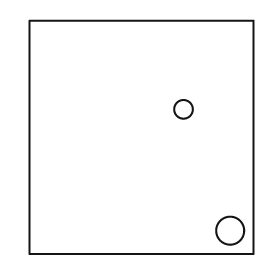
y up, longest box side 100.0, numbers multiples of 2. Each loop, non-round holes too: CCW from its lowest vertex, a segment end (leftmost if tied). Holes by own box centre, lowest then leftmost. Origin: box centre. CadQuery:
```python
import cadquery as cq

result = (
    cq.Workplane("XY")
    .moveTo(-48.0, -50.0)
    .lineTo(48.0, -50.0)
    .lineTo(48.0, 50.0)
    .lineTo(-48.0, 50.0)
    .close()
    .moveTo(38.0, -40.0)
    .circle(6.0)
    .moveTo(18.0, 12.0)
    .circle(4.0)
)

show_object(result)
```